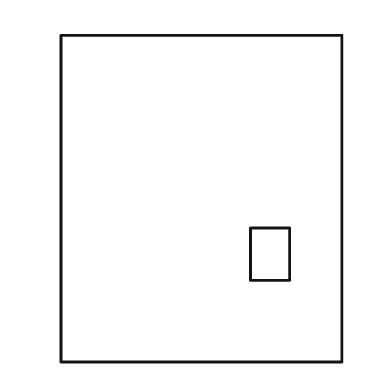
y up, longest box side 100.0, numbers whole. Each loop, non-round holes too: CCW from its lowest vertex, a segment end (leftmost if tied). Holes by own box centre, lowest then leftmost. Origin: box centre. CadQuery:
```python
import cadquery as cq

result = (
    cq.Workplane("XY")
    .moveTo(-43.0, -50.0)
    .lineTo(43.0, -50.0)
    .lineTo(43.0, 50.0)
    .lineTo(-43.0, 50.0)
    .close()
    .moveTo(15.0, -25.0)
    .lineTo(27.0, -25.0)
    .lineTo(27.0, -9.0)
    .lineTo(15.0, -9.0)
    .close()
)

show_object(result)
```